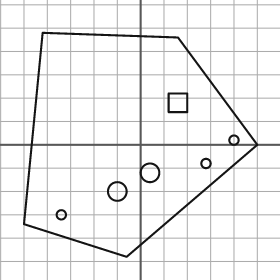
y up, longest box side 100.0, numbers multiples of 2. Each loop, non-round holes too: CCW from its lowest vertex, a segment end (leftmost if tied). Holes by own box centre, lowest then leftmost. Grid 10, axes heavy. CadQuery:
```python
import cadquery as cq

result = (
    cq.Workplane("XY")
    .moveTo(-6.0, -48.0)
    .lineTo(50.0, 0.0)
    .lineTo(16.0, 46.0)
    .lineTo(-42.0, 48.0)
    .lineTo(-50.0, -34.0)
    .close()
    .moveTo(-34.0, -30.0)
    .circle(2.0)
    .moveTo(-10.0, -20.0)
    .circle(4.0)
    .moveTo(4.0, -12.0)
    .circle(4.0)
    .moveTo(28.0, -8.0)
    .circle(2.0)
    .moveTo(40.0, 2.0)
    .circle(2.0)
    .moveTo(12.0, 14.0)
    .lineTo(20.0, 14.0)
    .lineTo(20.0, 22.0)
    .lineTo(12.0, 22.0)
    .close()
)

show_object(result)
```